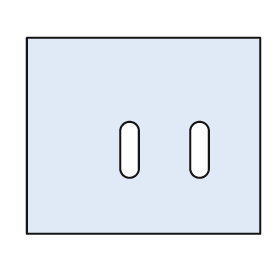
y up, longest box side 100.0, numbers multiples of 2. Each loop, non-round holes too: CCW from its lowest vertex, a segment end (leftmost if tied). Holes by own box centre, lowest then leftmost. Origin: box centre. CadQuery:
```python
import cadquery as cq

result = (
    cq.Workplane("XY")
    .moveTo(-50.0, -42.0)
    .lineTo(50.0, -42.0)
    .lineTo(50.0, 42.0)
    .lineTo(-50.0, 42.0)
    .close()
    .moveTo(-10.0, -14.0)
    .threePointArc((-6.0, -18.0), (-2.0, -14.0))
    .lineTo(-2.0, 2.0)
    .threePointArc((-6.0, 6.0), (-10.0, 2.0))
    .close()
    .moveTo(20.0, -14.0)
    .threePointArc((24.0, -18.0), (28.0, -14.0))
    .lineTo(28.0, 2.0)
    .threePointArc((24.0, 6.0), (20.0, 2.0))
    .close()
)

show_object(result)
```